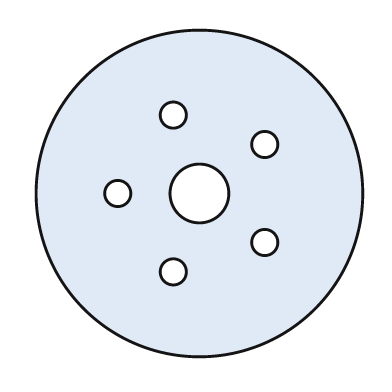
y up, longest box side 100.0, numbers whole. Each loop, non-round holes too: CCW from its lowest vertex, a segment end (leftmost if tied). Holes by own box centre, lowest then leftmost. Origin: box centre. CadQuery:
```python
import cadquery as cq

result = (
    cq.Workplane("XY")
    .moveTo(0.0, 0.0)
    .circle(50.0)
    .moveTo(-8.0, -24.0)
    .circle(4.0)
    .moveTo(20.0, -15.0)
    .circle(4.0)
    .moveTo(-25.0, 0.0)
    .circle(4.0)
    .moveTo(0.0, 0.0)
    .circle(9.0)
    .moveTo(20.0, 15.0)
    .circle(4.0)
    .moveTo(-8.0, 24.0)
    .circle(4.0)
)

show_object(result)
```